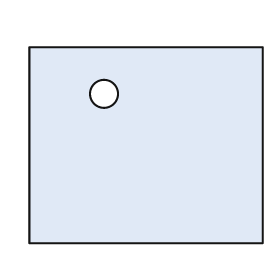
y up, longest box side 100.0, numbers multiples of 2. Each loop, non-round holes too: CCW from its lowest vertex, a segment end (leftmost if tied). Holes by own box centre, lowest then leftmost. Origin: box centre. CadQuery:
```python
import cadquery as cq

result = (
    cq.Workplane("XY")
    .moveTo(-50.0, -42.0)
    .lineTo(50.0, -42.0)
    .lineTo(50.0, 42.0)
    .lineTo(-50.0, 42.0)
    .close()
    .moveTo(-18.0, 22.0)
    .circle(6.0)
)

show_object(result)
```